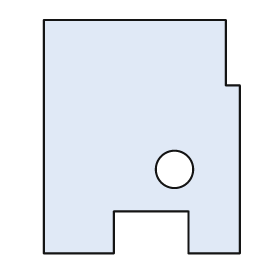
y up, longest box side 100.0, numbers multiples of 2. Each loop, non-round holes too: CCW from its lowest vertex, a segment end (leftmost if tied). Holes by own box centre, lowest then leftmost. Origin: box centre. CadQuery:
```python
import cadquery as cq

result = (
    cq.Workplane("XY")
    .moveTo(-42.0, -50.0)
    .lineTo(-12.0, -50.0)
    .lineTo(-12.0, -32.0)
    .lineTo(20.0, -32.0)
    .lineTo(20.0, -50.0)
    .lineTo(42.0, -50.0)
    .lineTo(42.0, 22.0)
    .lineTo(36.0, 22.0)
    .lineTo(36.0, 50.0)
    .lineTo(-42.0, 50.0)
    .close()
    .moveTo(14.0, -14.0)
    .circle(8.0)
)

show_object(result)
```